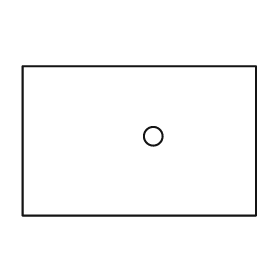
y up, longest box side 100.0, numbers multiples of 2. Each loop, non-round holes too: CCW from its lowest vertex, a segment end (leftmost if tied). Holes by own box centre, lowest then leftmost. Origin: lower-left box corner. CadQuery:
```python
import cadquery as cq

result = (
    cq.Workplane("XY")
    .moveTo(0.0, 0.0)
    .lineTo(100.0, 0.0)
    .lineTo(100.0, 64.0)
    .lineTo(0.0, 64.0)
    .close()
    .moveTo(56.0, 34.0)
    .circle(4.0)
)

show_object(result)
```